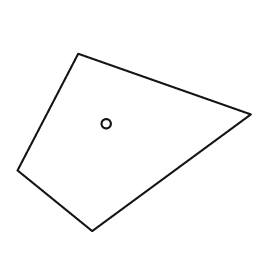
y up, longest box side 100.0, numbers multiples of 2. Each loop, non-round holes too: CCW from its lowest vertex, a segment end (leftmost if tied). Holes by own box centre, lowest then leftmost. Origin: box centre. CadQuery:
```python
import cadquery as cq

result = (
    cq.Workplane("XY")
    .moveTo(-18.0, -38.0)
    .lineTo(50.0, 12.0)
    .lineTo(-24.0, 38.0)
    .lineTo(-50.0, -12.0)
    .close()
    .moveTo(-12.0, 8.0)
    .circle(2.0)
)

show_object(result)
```